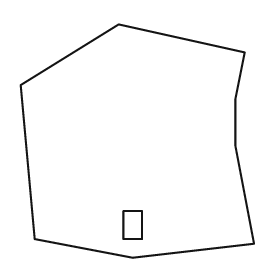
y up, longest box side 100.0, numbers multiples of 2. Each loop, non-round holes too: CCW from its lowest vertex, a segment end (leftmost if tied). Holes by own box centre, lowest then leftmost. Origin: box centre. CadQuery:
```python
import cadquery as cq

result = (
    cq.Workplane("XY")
    .moveTo(-2.0, -50.0)
    .lineTo(50.0, -44.0)
    .lineTo(42.0, -2.0)
    .lineTo(42.0, 18.0)
    .lineTo(46.0, 38.0)
    .lineTo(-8.0, 50.0)
    .lineTo(-50.0, 24.0)
    .lineTo(-44.0, -42.0)
    .close()
    .moveTo(-6.0, -42.0)
    .lineTo(2.0, -42.0)
    .lineTo(2.0, -30.0)
    .lineTo(-6.0, -30.0)
    .close()
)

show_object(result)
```